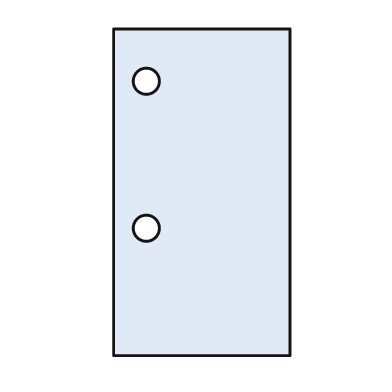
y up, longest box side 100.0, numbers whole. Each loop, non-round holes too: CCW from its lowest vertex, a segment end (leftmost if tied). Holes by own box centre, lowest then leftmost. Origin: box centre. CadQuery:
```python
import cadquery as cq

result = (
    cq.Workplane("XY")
    .moveTo(-27.0, -50.0)
    .lineTo(27.0, -50.0)
    .lineTo(27.0, 50.0)
    .lineTo(-27.0, 50.0)
    .close()
    .moveTo(-17.0, -11.0)
    .circle(4.0)
    .moveTo(-17.0, 34.0)
    .circle(4.0)
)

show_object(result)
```